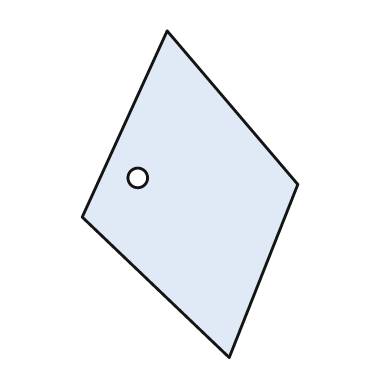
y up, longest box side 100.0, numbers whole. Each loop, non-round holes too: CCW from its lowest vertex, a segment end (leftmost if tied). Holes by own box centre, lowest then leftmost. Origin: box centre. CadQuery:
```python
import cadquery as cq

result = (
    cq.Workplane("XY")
    .moveTo(12.0, -50.0)
    .lineTo(33.0, 3.0)
    .lineTo(-7.0, 50.0)
    .lineTo(-33.0, -7.0)
    .close()
    .moveTo(-16.0, 5.0)
    .circle(3.0)
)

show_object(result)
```